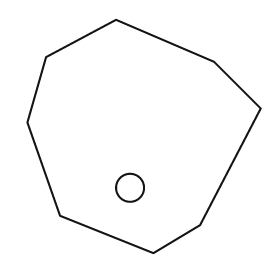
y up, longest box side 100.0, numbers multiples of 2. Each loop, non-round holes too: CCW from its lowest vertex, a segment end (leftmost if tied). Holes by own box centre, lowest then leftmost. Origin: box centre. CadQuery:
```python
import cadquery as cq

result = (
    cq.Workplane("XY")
    .moveTo(4.0, -50.0)
    .lineTo(24.0, -38.0)
    .lineTo(50.0, 12.0)
    .lineTo(30.0, 32.0)
    .lineTo(-12.0, 50.0)
    .lineTo(-42.0, 34.0)
    .lineTo(-50.0, 6.0)
    .lineTo(-36.0, -34.0)
    .close()
    .moveTo(-6.0, -22.0)
    .circle(6.0)
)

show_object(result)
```